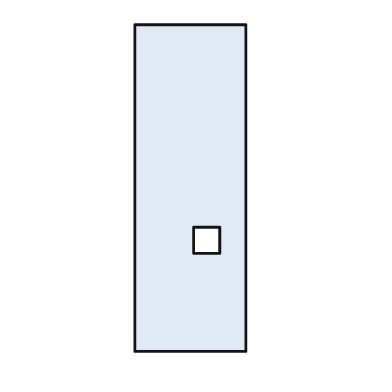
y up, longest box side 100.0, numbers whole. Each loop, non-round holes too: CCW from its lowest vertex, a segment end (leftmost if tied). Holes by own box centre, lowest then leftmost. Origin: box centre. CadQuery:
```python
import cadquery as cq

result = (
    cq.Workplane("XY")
    .moveTo(-17.0, -50.0)
    .lineTo(17.0, -50.0)
    .lineTo(17.0, 50.0)
    .lineTo(-17.0, 50.0)
    .close()
    .moveTo(1.0, -20.0)
    .lineTo(9.0, -20.0)
    .lineTo(9.0, -12.0)
    .lineTo(1.0, -12.0)
    .close()
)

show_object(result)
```